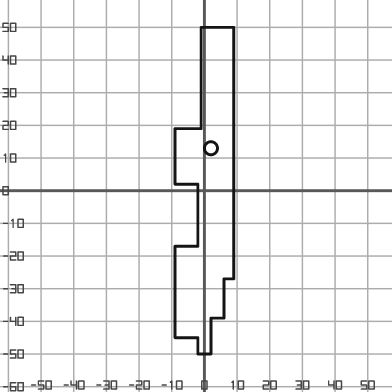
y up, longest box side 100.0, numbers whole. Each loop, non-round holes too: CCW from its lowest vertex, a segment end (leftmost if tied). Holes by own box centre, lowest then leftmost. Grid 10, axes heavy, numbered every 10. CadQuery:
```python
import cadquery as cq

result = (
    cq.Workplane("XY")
    .moveTo(-2.0, -50.0)
    .lineTo(2.0, -50.0)
    .lineTo(2.0, -39.0)
    .lineTo(6.0, -39.0)
    .lineTo(6.0, -27.0)
    .lineTo(9.0, -27.0)
    .lineTo(9.0, 50.0)
    .lineTo(-1.0, 50.0)
    .lineTo(-1.0, 19.0)
    .lineTo(-9.0, 19.0)
    .lineTo(-9.0, 2.0)
    .lineTo(-2.0, 2.0)
    .lineTo(-2.0, -17.0)
    .lineTo(-9.0, -17.0)
    .lineTo(-9.0, -45.0)
    .lineTo(-2.0, -45.0)
    .close()
    .moveTo(2.0, 13.0)
    .circle(2.0)
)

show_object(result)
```